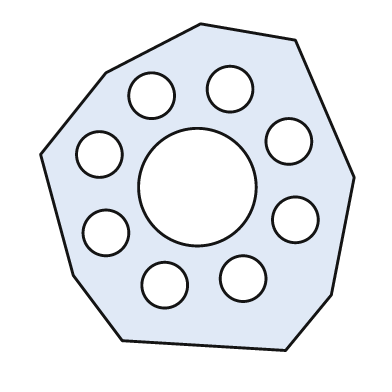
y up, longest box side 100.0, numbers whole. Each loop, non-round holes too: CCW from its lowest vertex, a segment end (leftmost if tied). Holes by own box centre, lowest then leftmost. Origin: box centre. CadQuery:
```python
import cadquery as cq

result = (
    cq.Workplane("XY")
    .moveTo(27.0, -50.0)
    .lineTo(41.0, -33.0)
    .lineTo(48.0, 3.0)
    .lineTo(30.0, 45.0)
    .lineTo(1.0, 50.0)
    .lineTo(-28.0, 35.0)
    .lineTo(-48.0, 10.0)
    .lineTo(-38.0, -27.0)
    .lineTo(-23.0, -47.0)
    .close()
    .moveTo(-10.0, -30.0)
    .circle(7.0)
    .moveTo(14.0, -28.0)
    .circle(7.0)
    .moveTo(-28.0, -14.0)
    .circle(7.0)
    .moveTo(30.0, -10.0)
    .circle(7.0)
    .moveTo(0.0, 0.0)
    .circle(18.0)
    .moveTo(-30.0, 10.0)
    .circle(7.0)
    .moveTo(28.0, 14.0)
    .circle(7.0)
    .moveTo(-14.0, 28.0)
    .circle(7.0)
    .moveTo(10.0, 30.0)
    .circle(7.0)
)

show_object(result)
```